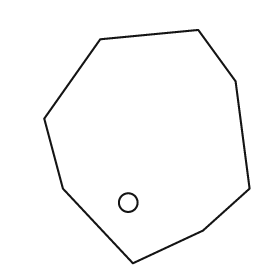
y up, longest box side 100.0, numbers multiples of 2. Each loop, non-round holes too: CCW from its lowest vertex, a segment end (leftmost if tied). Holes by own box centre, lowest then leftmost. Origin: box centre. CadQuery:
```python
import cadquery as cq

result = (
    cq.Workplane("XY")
    .moveTo(-6.0, -50.0)
    .lineTo(24.0, -36.0)
    .lineTo(44.0, -18.0)
    .lineTo(38.0, 28.0)
    .lineTo(22.0, 50.0)
    .lineTo(-20.0, 46.0)
    .lineTo(-44.0, 12.0)
    .lineTo(-36.0, -18.0)
    .close()
    .moveTo(-8.0, -24.0)
    .circle(4.0)
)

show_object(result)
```